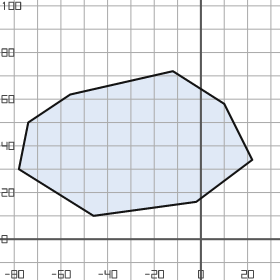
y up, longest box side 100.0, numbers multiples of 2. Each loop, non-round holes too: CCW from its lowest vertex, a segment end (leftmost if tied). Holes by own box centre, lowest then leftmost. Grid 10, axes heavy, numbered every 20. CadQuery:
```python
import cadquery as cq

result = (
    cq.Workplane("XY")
    .moveTo(-46.0, 10.0)
    .lineTo(-2.0, 16.0)
    .lineTo(22.0, 34.0)
    .lineTo(10.0, 58.0)
    .lineTo(-12.0, 72.0)
    .lineTo(-56.0, 62.0)
    .lineTo(-74.0, 50.0)
    .lineTo(-78.0, 30.0)
    .close()
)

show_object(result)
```